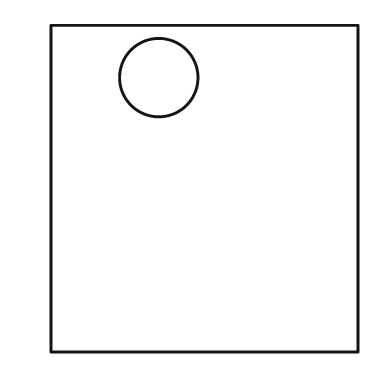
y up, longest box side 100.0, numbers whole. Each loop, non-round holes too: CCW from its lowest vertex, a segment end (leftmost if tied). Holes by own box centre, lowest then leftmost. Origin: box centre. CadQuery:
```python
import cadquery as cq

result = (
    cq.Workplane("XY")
    .moveTo(-47.0, -50.0)
    .lineTo(47.0, -50.0)
    .lineTo(47.0, 50.0)
    .lineTo(-47.0, 50.0)
    .close()
    .moveTo(-14.0, 34.0)
    .circle(12.0)
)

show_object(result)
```